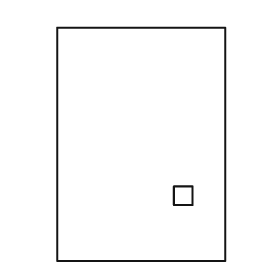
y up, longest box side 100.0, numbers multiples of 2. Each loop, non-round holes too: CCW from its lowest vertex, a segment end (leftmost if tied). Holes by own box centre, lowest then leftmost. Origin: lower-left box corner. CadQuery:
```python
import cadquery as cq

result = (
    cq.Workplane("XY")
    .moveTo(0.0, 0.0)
    .lineTo(72.0, 0.0)
    .lineTo(72.0, 100.0)
    .lineTo(0.0, 100.0)
    .close()
    .moveTo(50.0, 24.0)
    .lineTo(58.0, 24.0)
    .lineTo(58.0, 32.0)
    .lineTo(50.0, 32.0)
    .close()
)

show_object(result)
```